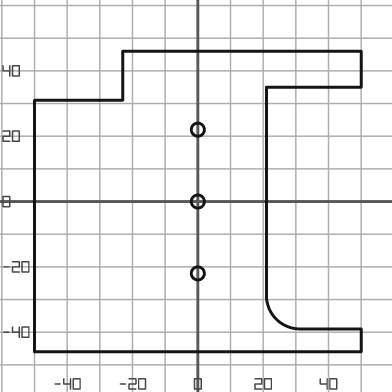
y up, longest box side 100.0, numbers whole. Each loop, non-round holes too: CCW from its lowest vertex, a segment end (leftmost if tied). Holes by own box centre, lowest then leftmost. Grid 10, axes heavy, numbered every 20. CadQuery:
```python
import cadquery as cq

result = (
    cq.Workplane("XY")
    .moveTo(-50.0, -46.0)
    .lineTo(50.0, -46.0)
    .lineTo(50.0, -39.0)
    .lineTo(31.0, -39.0)
    .threePointArc((24.0, -36.0), (21.0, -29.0))
    .lineTo(21.0, 35.0)
    .lineTo(50.0, 35.0)
    .lineTo(50.0, 46.0)
    .lineTo(-23.0, 46.0)
    .lineTo(-23.0, 31.0)
    .lineTo(-50.0, 31.0)
    .close()
    .moveTo(0.0, -22.0)
    .circle(2.0)
    .moveTo(0.0, 0.0)
    .circle(2.0)
    .moveTo(0.0, 22.0)
    .circle(2.0)
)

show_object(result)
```